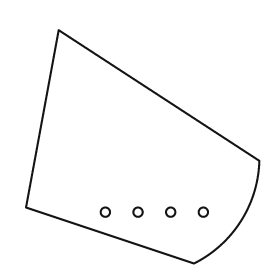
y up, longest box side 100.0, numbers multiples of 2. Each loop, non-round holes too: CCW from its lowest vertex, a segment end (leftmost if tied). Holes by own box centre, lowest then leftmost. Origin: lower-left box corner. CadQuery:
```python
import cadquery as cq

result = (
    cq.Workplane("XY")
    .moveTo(72.0, 0.0)
    .threePointArc((92.0, 18.0), (100.0, 44.0))
    .lineTo(14.0, 100.0)
    .lineTo(0.0, 24.0)
    .close()
    .moveTo(34.0, 22.0)
    .circle(2.0)
    .moveTo(48.0, 22.0)
    .circle(2.0)
    .moveTo(62.0, 22.0)
    .circle(2.0)
    .moveTo(76.0, 22.0)
    .circle(2.0)
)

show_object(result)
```